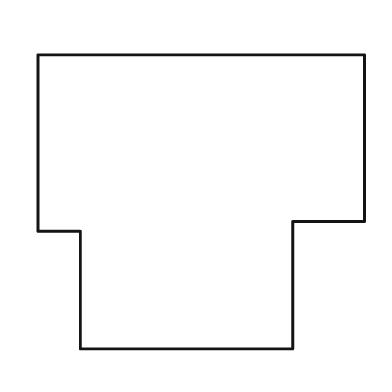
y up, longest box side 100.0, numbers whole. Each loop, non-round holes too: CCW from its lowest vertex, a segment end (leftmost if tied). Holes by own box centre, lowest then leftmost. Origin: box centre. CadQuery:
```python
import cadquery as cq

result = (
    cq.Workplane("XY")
    .moveTo(-37.0, -45.0)
    .lineTo(28.0, -45.0)
    .lineTo(28.0, -6.0)
    .lineTo(50.0, -6.0)
    .lineTo(50.0, 45.0)
    .lineTo(-50.0, 45.0)
    .lineTo(-50.0, -9.0)
    .lineTo(-37.0, -9.0)
    .close()
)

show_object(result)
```